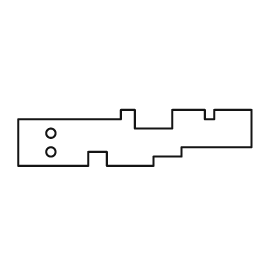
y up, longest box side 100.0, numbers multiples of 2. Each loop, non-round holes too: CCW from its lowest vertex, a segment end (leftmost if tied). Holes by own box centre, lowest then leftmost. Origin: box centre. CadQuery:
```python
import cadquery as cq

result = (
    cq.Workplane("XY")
    .moveTo(-50.0, -12.0)
    .lineTo(-20.0, -12.0)
    .lineTo(-20.0, -6.0)
    .lineTo(-12.0, -6.0)
    .lineTo(-12.0, -12.0)
    .lineTo(8.0, -12.0)
    .lineTo(8.0, -8.0)
    .lineTo(20.0, -8.0)
    .lineTo(20.0, -4.0)
    .lineTo(50.0, -4.0)
    .lineTo(50.0, 12.0)
    .lineTo(34.0, 12.0)
    .lineTo(34.0, 8.0)
    .lineTo(30.0, 8.0)
    .lineTo(30.0, 12.0)
    .lineTo(16.0, 12.0)
    .lineTo(16.0, 4.0)
    .lineTo(0.0, 4.0)
    .lineTo(0.0, 12.0)
    .lineTo(-6.0, 12.0)
    .lineTo(-6.0, 8.0)
    .lineTo(-50.0, 8.0)
    .close()
    .moveTo(-36.0, -6.0)
    .circle(2.0)
    .moveTo(-36.0, 2.0)
    .circle(2.0)
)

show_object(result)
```